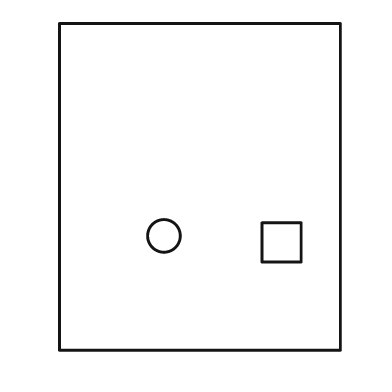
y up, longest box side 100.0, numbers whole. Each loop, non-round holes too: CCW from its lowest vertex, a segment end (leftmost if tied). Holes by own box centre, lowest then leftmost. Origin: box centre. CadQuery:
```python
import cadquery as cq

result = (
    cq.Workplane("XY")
    .moveTo(-43.0, -50.0)
    .lineTo(43.0, -50.0)
    .lineTo(43.0, 50.0)
    .lineTo(-43.0, 50.0)
    .close()
    .moveTo(19.0, -23.0)
    .lineTo(31.0, -23.0)
    .lineTo(31.0, -11.0)
    .lineTo(19.0, -11.0)
    .close()
    .moveTo(-11.0, -15.0)
    .circle(5.0)
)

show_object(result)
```